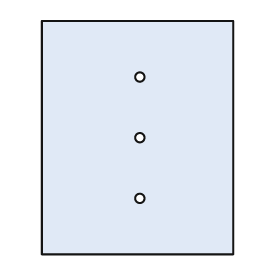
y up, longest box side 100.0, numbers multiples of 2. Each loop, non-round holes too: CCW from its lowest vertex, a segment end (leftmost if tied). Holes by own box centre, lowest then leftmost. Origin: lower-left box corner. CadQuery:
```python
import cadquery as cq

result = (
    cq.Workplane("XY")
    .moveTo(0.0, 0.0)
    .lineTo(82.0, 0.0)
    .lineTo(82.0, 100.0)
    .lineTo(0.0, 100.0)
    .close()
    .moveTo(42.0, 24.0)
    .circle(2.0)
    .moveTo(42.0, 50.0)
    .circle(2.0)
    .moveTo(42.0, 76.0)
    .circle(2.0)
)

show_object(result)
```